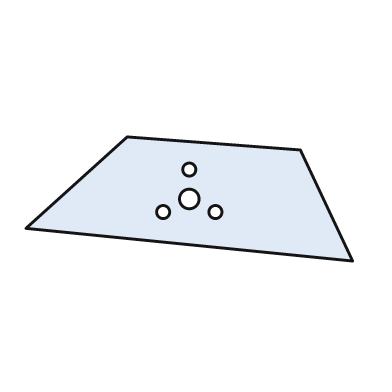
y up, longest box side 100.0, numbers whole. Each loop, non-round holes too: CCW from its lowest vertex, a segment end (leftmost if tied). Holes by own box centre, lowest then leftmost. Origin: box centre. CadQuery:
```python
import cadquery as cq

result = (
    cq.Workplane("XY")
    .moveTo(50.0, -19.0)
    .lineTo(34.0, 15.0)
    .lineTo(-19.0, 19.0)
    .lineTo(-50.0, -9.0)
    .close()
    .moveTo(-8.0, -4.0)
    .circle(2.0)
    .moveTo(8.0, -4.0)
    .circle(2.0)
    .moveTo(0.0, 0.0)
    .circle(3.0)
    .moveTo(0.0, 9.0)
    .circle(2.0)
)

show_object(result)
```